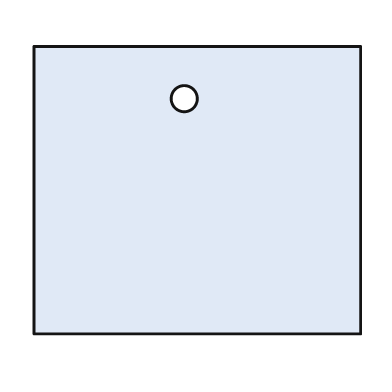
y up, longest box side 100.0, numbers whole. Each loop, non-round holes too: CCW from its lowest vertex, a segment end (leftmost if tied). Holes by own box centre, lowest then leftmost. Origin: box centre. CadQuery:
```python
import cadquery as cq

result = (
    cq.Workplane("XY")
    .moveTo(-50.0, -44.0)
    .lineTo(50.0, -44.0)
    .lineTo(50.0, 44.0)
    .lineTo(-50.0, 44.0)
    .close()
    .moveTo(-4.0, 28.0)
    .circle(4.0)
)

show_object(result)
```